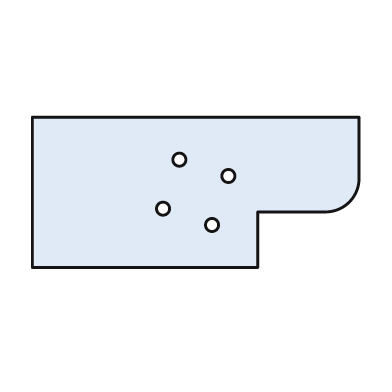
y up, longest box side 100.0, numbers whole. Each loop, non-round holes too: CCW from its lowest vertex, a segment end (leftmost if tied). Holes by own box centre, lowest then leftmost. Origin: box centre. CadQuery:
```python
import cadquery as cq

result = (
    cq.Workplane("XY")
    .moveTo(-50.0, -23.0)
    .lineTo(19.0, -23.0)
    .lineTo(19.0, -6.0)
    .lineTo(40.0, -6.0)
    .threePointArc((47.0, -3.0), (50.0, 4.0))
    .lineTo(50.0, 23.0)
    .lineTo(-50.0, 23.0)
    .close()
    .moveTo(5.0, -10.0)
    .circle(2.0)
    .moveTo(-10.0, -5.0)
    .circle(2.0)
    .moveTo(10.0, 5.0)
    .circle(2.0)
    .moveTo(-5.0, 10.0)
    .circle(2.0)
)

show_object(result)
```